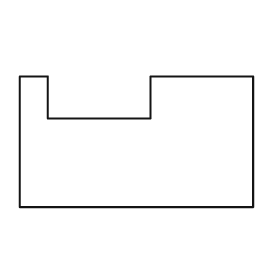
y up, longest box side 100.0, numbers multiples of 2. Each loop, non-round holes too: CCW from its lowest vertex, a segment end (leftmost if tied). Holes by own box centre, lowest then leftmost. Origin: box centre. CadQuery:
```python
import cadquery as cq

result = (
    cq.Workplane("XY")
    .moveTo(-50.0, -28.0)
    .lineTo(50.0, -28.0)
    .lineTo(50.0, 28.0)
    .lineTo(6.0, 28.0)
    .lineTo(6.0, 10.0)
    .lineTo(-38.0, 10.0)
    .lineTo(-38.0, 28.0)
    .lineTo(-50.0, 28.0)
    .close()
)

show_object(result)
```